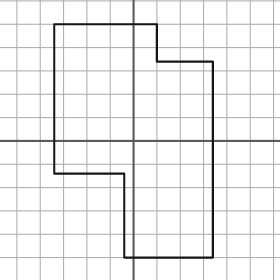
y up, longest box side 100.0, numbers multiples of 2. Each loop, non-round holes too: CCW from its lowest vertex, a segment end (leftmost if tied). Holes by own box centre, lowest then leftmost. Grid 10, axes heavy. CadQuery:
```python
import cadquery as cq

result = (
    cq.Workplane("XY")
    .moveTo(-4.0, -50.0)
    .lineTo(34.0, -50.0)
    .lineTo(34.0, 34.0)
    .lineTo(10.0, 34.0)
    .lineTo(10.0, 50.0)
    .lineTo(-34.0, 50.0)
    .lineTo(-34.0, -14.0)
    .lineTo(-4.0, -14.0)
    .close()
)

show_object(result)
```